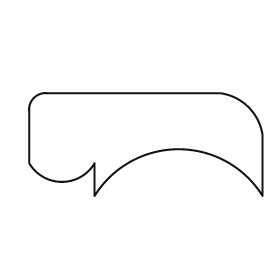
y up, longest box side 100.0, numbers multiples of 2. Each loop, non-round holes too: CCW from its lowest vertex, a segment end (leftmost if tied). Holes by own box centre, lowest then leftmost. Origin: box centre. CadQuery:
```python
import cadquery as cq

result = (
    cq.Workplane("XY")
    .moveTo(-22.0, -22.0)
    .threePointArc((14.0, -2.0), (50.0, -22.0))
    .lineTo(50.0, 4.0)
    .threePointArc((44.0, 16.0), (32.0, 22.0))
    .lineTo(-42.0, 22.0)
    .threePointArc((-48.0, 20.0), (-50.0, 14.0))
    .lineTo(-50.0, -8.0)
    .threePointArc((-36.0, -16.0), (-22.0, -8.0))
    .close()
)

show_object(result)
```